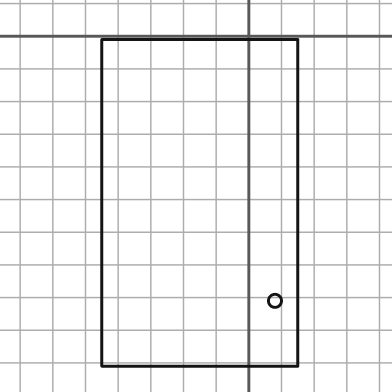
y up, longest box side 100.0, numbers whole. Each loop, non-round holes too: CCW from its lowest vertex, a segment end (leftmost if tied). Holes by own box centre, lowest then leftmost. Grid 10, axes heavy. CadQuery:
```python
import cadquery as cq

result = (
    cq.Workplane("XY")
    .moveTo(-45.0, -101.0)
    .lineTo(15.0, -101.0)
    .lineTo(15.0, -1.0)
    .lineTo(-45.0, -1.0)
    .close()
    .moveTo(8.0, -81.0)
    .circle(2.0)
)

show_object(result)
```